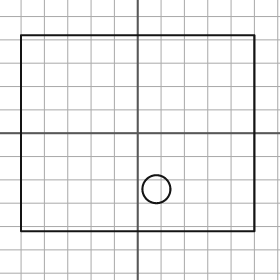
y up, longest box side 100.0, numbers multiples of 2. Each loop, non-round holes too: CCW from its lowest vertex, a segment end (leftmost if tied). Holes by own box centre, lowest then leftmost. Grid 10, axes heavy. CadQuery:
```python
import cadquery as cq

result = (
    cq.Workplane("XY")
    .moveTo(-50.0, -42.0)
    .lineTo(50.0, -42.0)
    .lineTo(50.0, 42.0)
    .lineTo(-50.0, 42.0)
    .close()
    .moveTo(8.0, -24.0)
    .circle(6.0)
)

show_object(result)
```